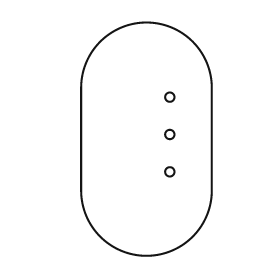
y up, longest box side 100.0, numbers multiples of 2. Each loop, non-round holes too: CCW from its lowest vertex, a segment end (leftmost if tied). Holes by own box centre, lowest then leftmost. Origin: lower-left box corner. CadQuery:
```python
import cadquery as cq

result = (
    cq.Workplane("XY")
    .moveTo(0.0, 28.0)
    .threePointArc((28.0, 0.0), (56.0, 28.0))
    .lineTo(56.0, 72.0)
    .threePointArc((28.0, 100.0), (0.0, 72.0))
    .close()
    .moveTo(38.0, 36.0)
    .circle(2.0)
    .moveTo(38.0, 52.0)
    .circle(2.0)
    .moveTo(38.0, 68.0)
    .circle(2.0)
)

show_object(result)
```